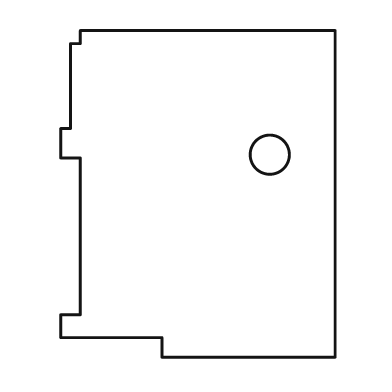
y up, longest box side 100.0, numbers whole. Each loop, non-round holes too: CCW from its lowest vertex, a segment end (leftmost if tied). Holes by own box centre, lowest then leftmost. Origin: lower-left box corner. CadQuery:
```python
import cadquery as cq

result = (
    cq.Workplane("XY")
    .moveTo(31.0, 0.0)
    .lineTo(84.0, 0.0)
    .lineTo(84.0, 100.0)
    .lineTo(6.0, 100.0)
    .lineTo(6.0, 96.0)
    .lineTo(3.0, 96.0)
    .lineTo(3.0, 70.0)
    .lineTo(0.0, 70.0)
    .lineTo(0.0, 61.0)
    .lineTo(6.0, 61.0)
    .lineTo(6.0, 13.0)
    .lineTo(0.0, 13.0)
    .lineTo(0.0, 6.0)
    .lineTo(31.0, 6.0)
    .close()
    .moveTo(64.0, 62.0)
    .circle(6.0)
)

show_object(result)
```